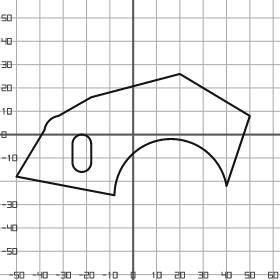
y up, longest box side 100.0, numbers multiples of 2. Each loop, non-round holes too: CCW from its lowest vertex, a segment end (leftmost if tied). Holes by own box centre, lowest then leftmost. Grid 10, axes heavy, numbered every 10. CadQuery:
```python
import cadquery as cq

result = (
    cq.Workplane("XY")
    .moveTo(-8.0, -26.0)
    .threePointArc((14.0, -2.0), (40.0, -22.0))
    .lineTo(50.0, 8.0)
    .lineTo(20.0, 26.0)
    .lineTo(-18.0, 16.0)
    .lineTo(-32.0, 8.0)
    .threePointArc((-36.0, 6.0), (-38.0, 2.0))
    .lineTo(-50.0, -18.0)
    .close()
    .moveTo(-26.0, -12.0)
    .threePointArc((-22.0, -16.0), (-18.0, -12.0))
    .lineTo(-18.0, -4.0)
    .threePointArc((-22.0, 0.0), (-26.0, -4.0))
    .close()
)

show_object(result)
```